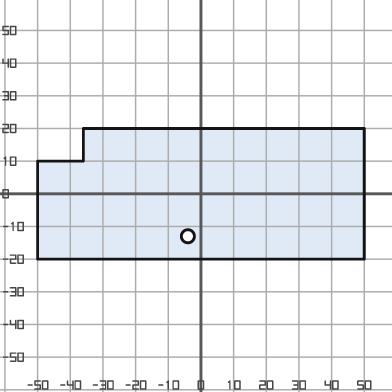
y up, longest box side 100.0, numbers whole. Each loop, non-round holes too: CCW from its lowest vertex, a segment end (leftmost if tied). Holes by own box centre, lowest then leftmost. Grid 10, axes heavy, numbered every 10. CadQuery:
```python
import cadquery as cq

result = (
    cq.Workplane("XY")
    .moveTo(-50.0, -20.0)
    .lineTo(50.0, -20.0)
    .lineTo(50.0, 20.0)
    .lineTo(-36.0, 20.0)
    .lineTo(-36.0, 10.0)
    .lineTo(-50.0, 10.0)
    .close()
    .moveTo(-4.0, -13.0)
    .circle(2.0)
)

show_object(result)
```